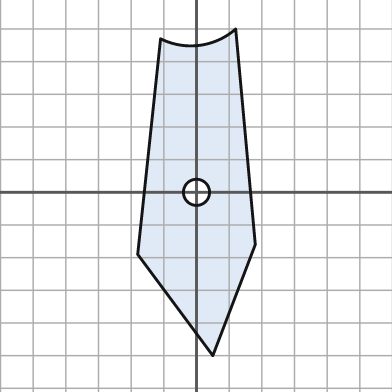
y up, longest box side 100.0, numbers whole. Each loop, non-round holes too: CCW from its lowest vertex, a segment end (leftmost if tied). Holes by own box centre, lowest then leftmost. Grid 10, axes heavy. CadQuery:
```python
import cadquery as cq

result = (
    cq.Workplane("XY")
    .moveTo(5.0, -50.0)
    .lineTo(18.0, -16.0)
    .lineTo(12.0, 50.0)
    .threePointArc((1.0, 45.0), (-11.0, 47.0))
    .lineTo(-18.0, -19.0)
    .close()
    .moveTo(0.0, 0.0)
    .circle(4.0)
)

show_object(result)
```